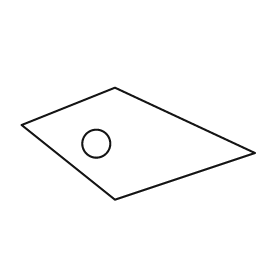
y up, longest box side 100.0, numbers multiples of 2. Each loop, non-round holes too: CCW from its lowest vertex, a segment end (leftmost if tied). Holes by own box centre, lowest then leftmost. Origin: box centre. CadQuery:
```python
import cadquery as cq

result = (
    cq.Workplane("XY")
    .moveTo(-10.0, -24.0)
    .lineTo(50.0, -4.0)
    .lineTo(-10.0, 24.0)
    .lineTo(-50.0, 8.0)
    .close()
    .moveTo(-18.0, 0.0)
    .circle(6.0)
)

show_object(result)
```